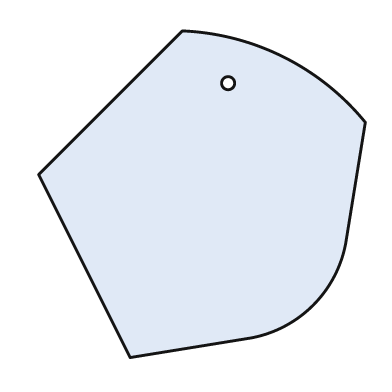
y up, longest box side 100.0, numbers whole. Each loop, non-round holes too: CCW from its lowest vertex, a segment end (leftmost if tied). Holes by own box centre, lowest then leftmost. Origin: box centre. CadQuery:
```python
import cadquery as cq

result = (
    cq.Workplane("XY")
    .moveTo(-22.0, -50.0)
    .lineTo(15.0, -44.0)
    .threePointArc((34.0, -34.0), (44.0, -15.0))
    .lineTo(50.0, 22.0)
    .threePointArc((25.0, 42.0), (-6.0, 50.0))
    .lineTo(-50.0, 6.0)
    .close()
    .moveTo(8.0, 34.0)
    .circle(2.0)
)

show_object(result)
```